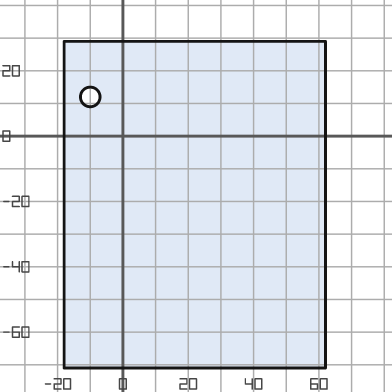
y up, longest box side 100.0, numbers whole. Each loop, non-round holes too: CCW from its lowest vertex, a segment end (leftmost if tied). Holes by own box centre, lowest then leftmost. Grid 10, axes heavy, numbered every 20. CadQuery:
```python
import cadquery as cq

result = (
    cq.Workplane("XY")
    .moveTo(-18.0, -71.0)
    .lineTo(62.0, -71.0)
    .lineTo(62.0, 29.0)
    .lineTo(-18.0, 29.0)
    .close()
    .moveTo(-10.0, 12.0)
    .circle(3.0)
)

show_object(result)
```